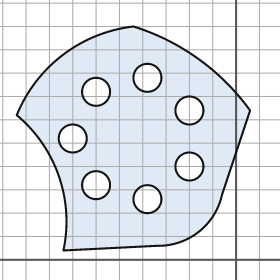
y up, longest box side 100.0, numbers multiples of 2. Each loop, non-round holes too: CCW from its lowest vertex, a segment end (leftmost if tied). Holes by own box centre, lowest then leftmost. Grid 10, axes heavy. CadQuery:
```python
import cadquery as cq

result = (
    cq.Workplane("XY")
    .moveTo(-74.0, 4.0)
    .lineTo(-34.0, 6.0)
    .threePointArc((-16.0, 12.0), (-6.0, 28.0))
    .lineTo(6.0, 64.0)
    .threePointArc((-16.0, 86.0), (-44.0, 100.0))
    .threePointArc((-74.0, 88.0), (-94.0, 62.0))
    .threePointArc((-76.0, 36.0), (-74.0, 4.0))
    .close()
    .moveTo(-38.0, 26.0)
    .circle(6.0)
    .moveTo(-60.0, 32.0)
    .circle(6.0)
    .moveTo(-20.0, 40.0)
    .circle(6.0)
    .moveTo(-70.0, 52.0)
    .circle(6.0)
    .moveTo(-20.0, 64.0)
    .circle(6.0)
    .moveTo(-60.0, 72.0)
    .circle(6.0)
    .moveTo(-38.0, 78.0)
    .circle(6.0)
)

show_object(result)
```